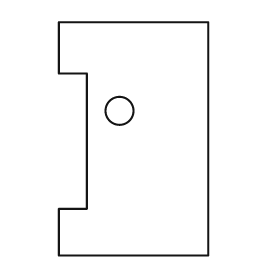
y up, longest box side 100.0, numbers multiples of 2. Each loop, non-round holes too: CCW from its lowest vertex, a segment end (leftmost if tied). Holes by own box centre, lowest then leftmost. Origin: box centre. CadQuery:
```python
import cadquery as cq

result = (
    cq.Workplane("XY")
    .moveTo(-32.0, -50.0)
    .lineTo(32.0, -50.0)
    .lineTo(32.0, 50.0)
    .lineTo(-32.0, 50.0)
    .lineTo(-32.0, 28.0)
    .lineTo(-20.0, 28.0)
    .lineTo(-20.0, -30.0)
    .lineTo(-32.0, -30.0)
    .close()
    .moveTo(-6.0, 12.0)
    .circle(6.0)
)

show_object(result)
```